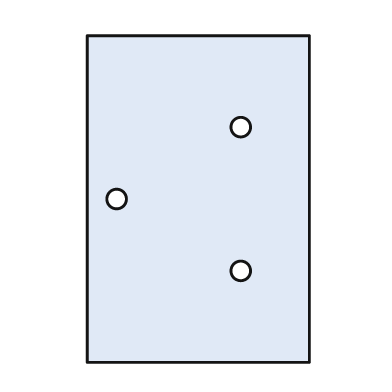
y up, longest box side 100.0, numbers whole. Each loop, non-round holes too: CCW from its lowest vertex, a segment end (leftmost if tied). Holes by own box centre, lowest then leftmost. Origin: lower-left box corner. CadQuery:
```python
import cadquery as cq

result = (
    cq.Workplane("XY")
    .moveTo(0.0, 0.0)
    .lineTo(68.0, 0.0)
    .lineTo(68.0, 100.0)
    .lineTo(0.0, 100.0)
    .close()
    .moveTo(47.0, 28.0)
    .circle(3.0)
    .moveTo(9.0, 50.0)
    .circle(3.0)
    .moveTo(47.0, 72.0)
    .circle(3.0)
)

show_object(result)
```